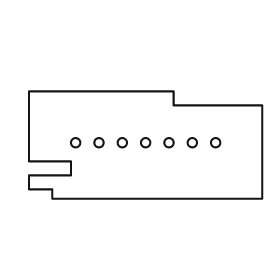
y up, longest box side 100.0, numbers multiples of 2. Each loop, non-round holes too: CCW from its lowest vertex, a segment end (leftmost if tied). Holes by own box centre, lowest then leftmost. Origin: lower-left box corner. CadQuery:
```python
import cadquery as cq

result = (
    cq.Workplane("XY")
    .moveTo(10.0, 0.0)
    .lineTo(100.0, 0.0)
    .lineTo(100.0, 40.0)
    .lineTo(62.0, 40.0)
    .lineTo(62.0, 46.0)
    .lineTo(0.0, 46.0)
    .lineTo(0.0, 16.0)
    .lineTo(18.0, 16.0)
    .lineTo(18.0, 10.0)
    .lineTo(0.0, 10.0)
    .lineTo(0.0, 4.0)
    .lineTo(10.0, 4.0)
    .close()
    .moveTo(20.0, 24.0)
    .circle(2.0)
    .moveTo(30.0, 24.0)
    .circle(2.0)
    .moveTo(40.0, 24.0)
    .circle(2.0)
    .moveTo(50.0, 24.0)
    .circle(2.0)
    .moveTo(60.0, 24.0)
    .circle(2.0)
    .moveTo(70.0, 24.0)
    .circle(2.0)
    .moveTo(80.0, 24.0)
    .circle(2.0)
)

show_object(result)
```